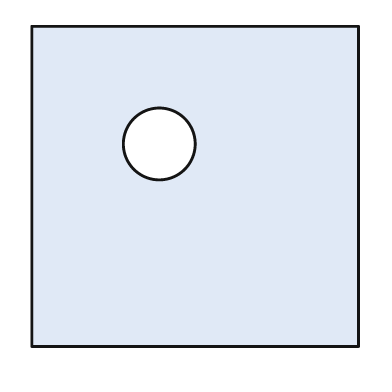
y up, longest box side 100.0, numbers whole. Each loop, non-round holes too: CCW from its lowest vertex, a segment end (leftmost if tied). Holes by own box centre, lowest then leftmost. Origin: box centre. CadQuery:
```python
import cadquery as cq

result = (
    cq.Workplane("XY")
    .moveTo(-50.0, -49.0)
    .lineTo(50.0, -49.0)
    .lineTo(50.0, 49.0)
    .lineTo(-50.0, 49.0)
    .close()
    .moveTo(-11.0, 13.0)
    .circle(11.0)
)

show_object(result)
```